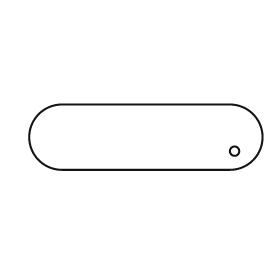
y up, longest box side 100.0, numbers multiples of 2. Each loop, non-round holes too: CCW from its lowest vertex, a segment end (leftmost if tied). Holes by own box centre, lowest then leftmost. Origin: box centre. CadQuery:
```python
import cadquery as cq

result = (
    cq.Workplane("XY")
    .moveTo(-36.0, -14.0)
    .lineTo(36.0, -14.0)
    .threePointArc((50.0, 0.0), (36.0, 14.0))
    .lineTo(-36.0, 14.0)
    .threePointArc((-50.0, 0.0), (-36.0, -14.0))
    .close()
    .moveTo(38.0, -6.0)
    .circle(2.0)
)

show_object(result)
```